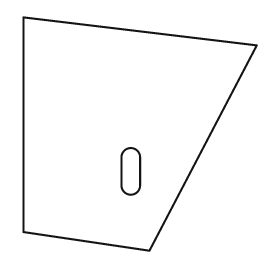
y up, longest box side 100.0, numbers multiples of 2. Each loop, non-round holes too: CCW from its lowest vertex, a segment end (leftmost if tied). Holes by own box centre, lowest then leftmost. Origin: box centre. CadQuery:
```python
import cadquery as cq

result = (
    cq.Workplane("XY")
    .moveTo(4.0, -50.0)
    .lineTo(50.0, 38.0)
    .lineTo(-50.0, 50.0)
    .lineTo(-50.0, -42.0)
    .close()
    .moveTo(-8.0, -22.0)
    .threePointArc((-4.0, -26.0), (0.0, -22.0))
    .lineTo(0.0, -10.0)
    .threePointArc((-4.0, -6.0), (-8.0, -10.0))
    .close()
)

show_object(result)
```